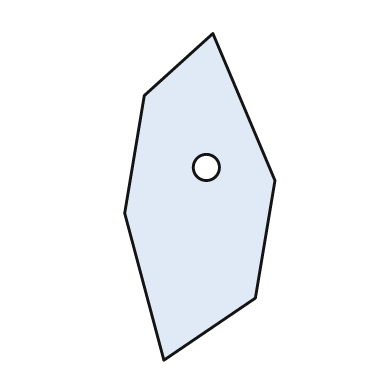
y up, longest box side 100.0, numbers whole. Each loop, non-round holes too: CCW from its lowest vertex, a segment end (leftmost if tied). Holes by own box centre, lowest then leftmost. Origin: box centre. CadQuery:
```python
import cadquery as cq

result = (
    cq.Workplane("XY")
    .moveTo(-11.0, -50.0)
    .lineTo(17.0, -31.0)
    .lineTo(23.0, 5.0)
    .lineTo(4.0, 50.0)
    .lineTo(-17.0, 31.0)
    .lineTo(-23.0, -5.0)
    .close()
    .moveTo(2.0, 9.0)
    .circle(4.0)
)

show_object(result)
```